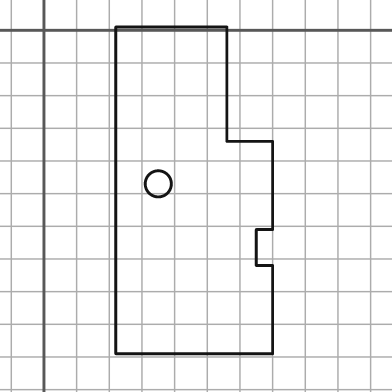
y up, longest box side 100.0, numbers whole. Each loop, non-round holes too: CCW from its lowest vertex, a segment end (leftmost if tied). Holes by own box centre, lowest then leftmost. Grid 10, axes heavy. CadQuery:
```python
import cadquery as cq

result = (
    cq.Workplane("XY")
    .moveTo(22.0, -99.0)
    .lineTo(70.0, -99.0)
    .lineTo(70.0, -72.0)
    .lineTo(65.0, -72.0)
    .lineTo(65.0, -61.0)
    .lineTo(70.0, -61.0)
    .lineTo(70.0, -34.0)
    .lineTo(56.0, -34.0)
    .lineTo(56.0, 1.0)
    .lineTo(22.0, 1.0)
    .close()
    .moveTo(35.0, -47.0)
    .circle(4.0)
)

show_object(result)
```